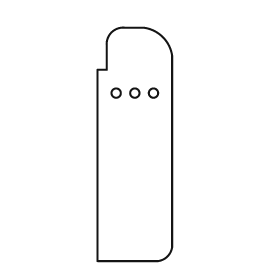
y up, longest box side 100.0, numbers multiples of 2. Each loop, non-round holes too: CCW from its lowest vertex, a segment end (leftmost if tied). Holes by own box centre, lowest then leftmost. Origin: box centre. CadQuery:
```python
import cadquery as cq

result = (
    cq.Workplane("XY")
    .moveTo(-16.0, -50.0)
    .lineTo(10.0, -50.0)
    .threePointArc((14.0, -48.0), (16.0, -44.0))
    .lineTo(16.0, 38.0)
    .threePointArc((12.0, 46.0), (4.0, 50.0))
    .lineTo(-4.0, 50.0)
    .threePointArc((-10.0, 48.0), (-12.0, 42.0))
    .lineTo(-12.0, 32.0)
    .lineTo(-16.0, 32.0)
    .close()
    .moveTo(-8.0, 22.0)
    .circle(2.0)
    .moveTo(0.0, 22.0)
    .circle(2.0)
    .moveTo(8.0, 22.0)
    .circle(2.0)
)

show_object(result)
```